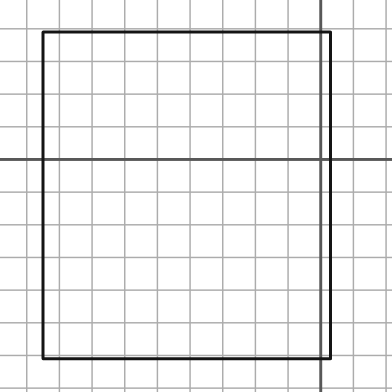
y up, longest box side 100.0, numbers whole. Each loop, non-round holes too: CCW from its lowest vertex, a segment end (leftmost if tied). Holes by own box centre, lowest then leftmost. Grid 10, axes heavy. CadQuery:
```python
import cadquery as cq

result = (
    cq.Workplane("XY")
    .moveTo(-85.0, -61.0)
    .lineTo(3.0, -61.0)
    .lineTo(3.0, 39.0)
    .lineTo(-85.0, 39.0)
    .close()
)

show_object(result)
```